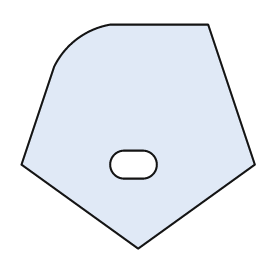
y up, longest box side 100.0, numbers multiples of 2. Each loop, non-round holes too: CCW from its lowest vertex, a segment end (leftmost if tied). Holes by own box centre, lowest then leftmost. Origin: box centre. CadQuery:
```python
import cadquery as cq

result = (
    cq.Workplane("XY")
    .moveTo(0.0, -48.0)
    .lineTo(50.0, -12.0)
    .lineTo(30.0, 48.0)
    .lineTo(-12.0, 48.0)
    .threePointArc((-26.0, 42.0), (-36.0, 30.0))
    .lineTo(-50.0, -12.0)
    .close()
    .moveTo(-6.0, -18.0)
    .lineTo(2.0, -18.0)
    .threePointArc((8.0, -12.0), (2.0, -6.0))
    .lineTo(-6.0, -6.0)
    .threePointArc((-12.0, -12.0), (-6.0, -18.0))
    .close()
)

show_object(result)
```